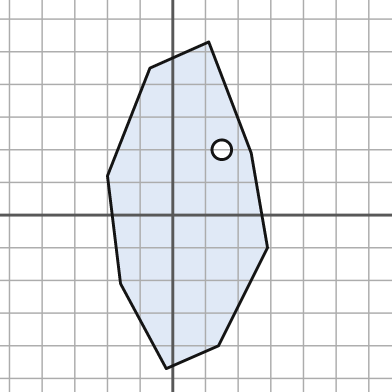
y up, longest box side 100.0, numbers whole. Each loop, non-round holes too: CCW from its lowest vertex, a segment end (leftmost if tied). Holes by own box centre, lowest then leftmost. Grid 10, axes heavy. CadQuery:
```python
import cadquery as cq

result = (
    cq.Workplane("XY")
    .moveTo(-2.0, -47.0)
    .lineTo(14.0, -40.0)
    .lineTo(29.0, -10.0)
    .lineTo(24.0, 19.0)
    .lineTo(11.0, 53.0)
    .lineTo(-7.0, 45.0)
    .lineTo(-20.0, 12.0)
    .lineTo(-16.0, -21.0)
    .close()
    .moveTo(15.0, 20.0)
    .circle(3.0)
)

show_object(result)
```